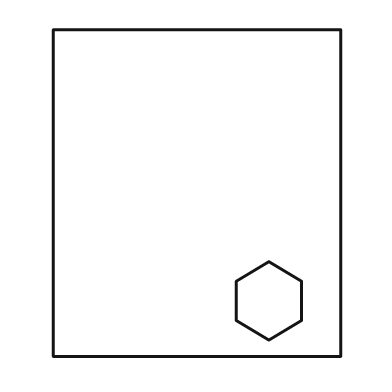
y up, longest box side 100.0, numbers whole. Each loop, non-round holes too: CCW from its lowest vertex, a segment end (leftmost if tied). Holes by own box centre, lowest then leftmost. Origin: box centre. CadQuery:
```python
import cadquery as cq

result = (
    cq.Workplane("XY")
    .moveTo(-44.0, -50.0)
    .lineTo(44.0, -50.0)
    .lineTo(44.0, 50.0)
    .lineTo(-44.0, 50.0)
    .close()
    .moveTo(22.0, -45.0)
    .lineTo(32.0, -39.0)
    .lineTo(32.0, -27.0)
    .lineTo(22.0, -21.0)
    .lineTo(12.0, -27.0)
    .lineTo(12.0, -39.0)
    .close()
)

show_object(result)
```